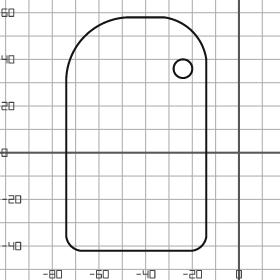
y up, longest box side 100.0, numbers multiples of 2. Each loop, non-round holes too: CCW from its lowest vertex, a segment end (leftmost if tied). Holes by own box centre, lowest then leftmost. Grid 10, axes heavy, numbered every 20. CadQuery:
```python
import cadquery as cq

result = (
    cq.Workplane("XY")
    .moveTo(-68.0, -42.0)
    .lineTo(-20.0, -42.0)
    .threePointArc((-16.0, -40.0), (-14.0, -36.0))
    .lineTo(-14.0, 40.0)
    .threePointArc((-20.0, 52.0), (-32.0, 58.0))
    .lineTo(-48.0, 58.0)
    .threePointArc((-66.0, 50.0), (-74.0, 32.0))
    .lineTo(-74.0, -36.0)
    .threePointArc((-72.0, -40.0), (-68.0, -42.0))
    .close()
    .moveTo(-24.0, 36.0)
    .circle(4.0)
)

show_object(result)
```